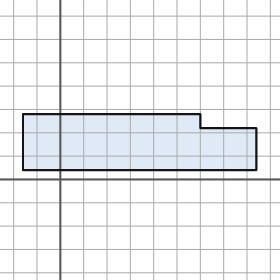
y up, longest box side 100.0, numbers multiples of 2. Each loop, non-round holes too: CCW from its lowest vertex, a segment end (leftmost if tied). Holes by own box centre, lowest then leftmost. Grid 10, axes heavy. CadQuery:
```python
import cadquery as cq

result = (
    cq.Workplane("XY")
    .moveTo(-16.0, 4.0)
    .lineTo(84.0, 4.0)
    .lineTo(84.0, 22.0)
    .lineTo(60.0, 22.0)
    .lineTo(60.0, 28.0)
    .lineTo(-16.0, 28.0)
    .close()
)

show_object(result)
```